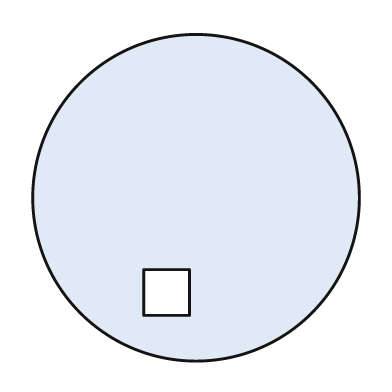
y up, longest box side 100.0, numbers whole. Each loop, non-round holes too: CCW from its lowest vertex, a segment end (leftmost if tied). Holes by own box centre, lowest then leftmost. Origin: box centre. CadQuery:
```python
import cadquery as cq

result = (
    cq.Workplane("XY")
    .moveTo(0.0, 0.0)
    .circle(50.0)
    .moveTo(-16.0, -36.0)
    .lineTo(-2.0, -36.0)
    .lineTo(-2.0, -22.0)
    .lineTo(-16.0, -22.0)
    .close()
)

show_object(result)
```